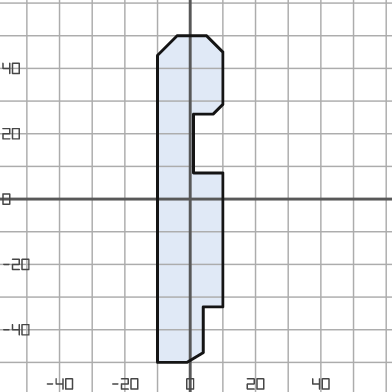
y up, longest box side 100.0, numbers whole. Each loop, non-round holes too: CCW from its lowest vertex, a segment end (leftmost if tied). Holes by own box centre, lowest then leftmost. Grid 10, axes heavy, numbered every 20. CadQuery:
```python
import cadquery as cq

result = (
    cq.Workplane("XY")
    .moveTo(-10.0, -50.0)
    .lineTo(-1.0, -50.0)
    .lineTo(4.0, -47.0)
    .lineTo(4.0, -33.0)
    .lineTo(10.0, -33.0)
    .lineTo(10.0, 8.0)
    .lineTo(1.0, 8.0)
    .lineTo(1.0, 26.0)
    .lineTo(7.0, 26.0)
    .lineTo(10.0, 29.0)
    .lineTo(10.0, 45.0)
    .lineTo(5.0, 50.0)
    .lineTo(-4.0, 50.0)
    .lineTo(-10.0, 44.0)
    .close()
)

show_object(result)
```